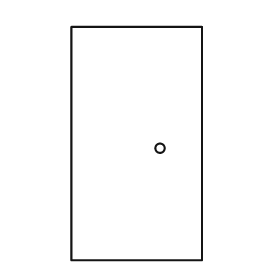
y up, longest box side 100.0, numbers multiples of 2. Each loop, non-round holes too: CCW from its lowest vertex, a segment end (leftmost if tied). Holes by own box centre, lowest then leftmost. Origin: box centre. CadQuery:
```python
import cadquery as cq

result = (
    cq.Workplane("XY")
    .moveTo(-28.0, -50.0)
    .lineTo(28.0, -50.0)
    .lineTo(28.0, 50.0)
    .lineTo(-28.0, 50.0)
    .close()
    .moveTo(10.0, -2.0)
    .circle(2.0)
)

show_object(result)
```